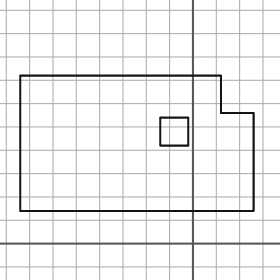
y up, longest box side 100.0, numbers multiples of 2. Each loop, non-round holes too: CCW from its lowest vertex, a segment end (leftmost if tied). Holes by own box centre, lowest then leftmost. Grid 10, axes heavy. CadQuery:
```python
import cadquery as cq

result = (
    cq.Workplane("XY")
    .moveTo(-74.0, 14.0)
    .lineTo(26.0, 14.0)
    .lineTo(26.0, 56.0)
    .lineTo(12.0, 56.0)
    .lineTo(12.0, 72.0)
    .lineTo(-74.0, 72.0)
    .close()
    .moveTo(-14.0, 42.0)
    .lineTo(-2.0, 42.0)
    .lineTo(-2.0, 54.0)
    .lineTo(-14.0, 54.0)
    .close()
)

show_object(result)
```